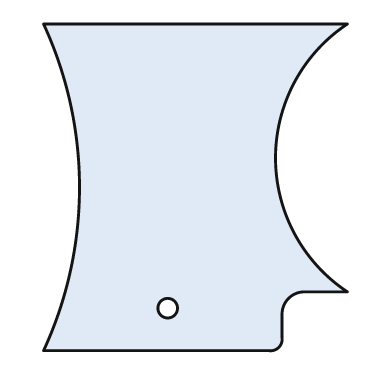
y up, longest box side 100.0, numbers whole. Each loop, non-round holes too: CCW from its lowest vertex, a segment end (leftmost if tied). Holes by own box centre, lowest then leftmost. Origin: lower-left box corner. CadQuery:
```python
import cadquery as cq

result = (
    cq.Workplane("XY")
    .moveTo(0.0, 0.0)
    .lineTo(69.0, 0.0)
    .threePointArc((72.0, 1.0), (73.0, 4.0))
    .lineTo(73.0, 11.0)
    .threePointArc((75.0, 16.0), (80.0, 18.0))
    .lineTo(93.0, 18.0)
    .threePointArc((71.0, 59.0), (93.0, 100.0))
    .lineTo(0.0, 100.0)
    .threePointArc((11.0, 50.0), (0.0, 0.0))
    .close()
    .moveTo(38.0, 13.0)
    .circle(3.0)
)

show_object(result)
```